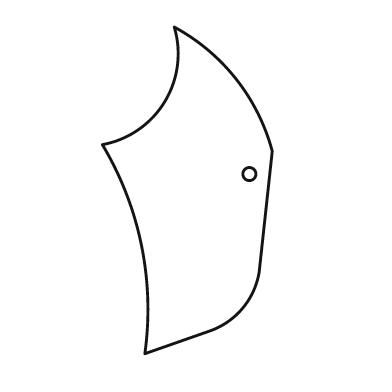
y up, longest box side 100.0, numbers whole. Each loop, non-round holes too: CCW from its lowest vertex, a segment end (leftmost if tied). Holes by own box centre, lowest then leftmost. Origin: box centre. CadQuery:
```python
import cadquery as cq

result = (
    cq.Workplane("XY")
    .moveTo(-13.0, -50.0)
    .lineTo(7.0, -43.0)
    .threePointArc((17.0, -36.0), (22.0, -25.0))
    .lineTo(26.0, 12.0)
    .threePointArc((15.0, 34.0), (-4.0, 50.0))
    .threePointArc((-7.0, 27.0), (-26.0, 14.0))
    .threePointArc((-14.0, -17.0), (-13.0, -50.0))
    .close()
    .moveTo(19.0, 5.0)
    .circle(2.0)
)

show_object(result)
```